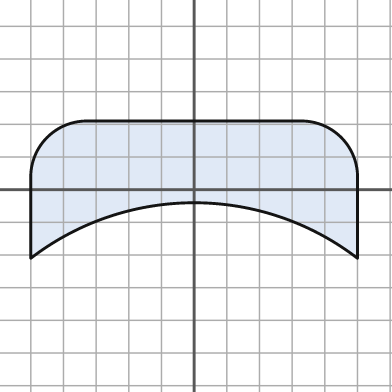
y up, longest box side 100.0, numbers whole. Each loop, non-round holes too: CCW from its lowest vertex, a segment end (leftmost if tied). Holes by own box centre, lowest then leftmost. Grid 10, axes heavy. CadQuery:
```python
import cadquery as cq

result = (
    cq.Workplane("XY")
    .moveTo(-50.0, -21.0)
    .threePointArc((0.0, -4.0), (50.0, -21.0))
    .lineTo(50.0, 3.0)
    .threePointArc((45.0, 16.0), (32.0, 21.0))
    .lineTo(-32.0, 21.0)
    .threePointArc((-45.0, 16.0), (-50.0, 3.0))
    .close()
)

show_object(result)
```